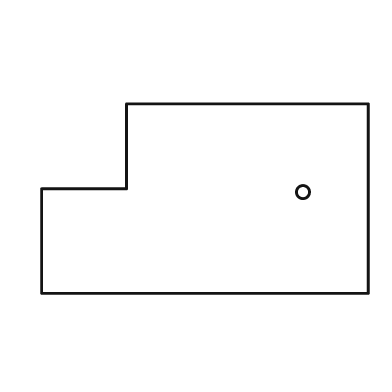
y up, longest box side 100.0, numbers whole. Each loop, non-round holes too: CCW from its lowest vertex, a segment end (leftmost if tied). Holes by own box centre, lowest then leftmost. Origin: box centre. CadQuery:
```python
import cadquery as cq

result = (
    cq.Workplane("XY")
    .moveTo(-50.0, -29.0)
    .lineTo(50.0, -29.0)
    .lineTo(50.0, 29.0)
    .lineTo(-24.0, 29.0)
    .lineTo(-24.0, 3.0)
    .lineTo(-50.0, 3.0)
    .close()
    .moveTo(30.0, 2.0)
    .circle(2.0)
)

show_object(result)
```